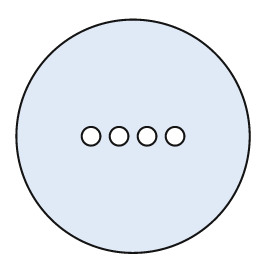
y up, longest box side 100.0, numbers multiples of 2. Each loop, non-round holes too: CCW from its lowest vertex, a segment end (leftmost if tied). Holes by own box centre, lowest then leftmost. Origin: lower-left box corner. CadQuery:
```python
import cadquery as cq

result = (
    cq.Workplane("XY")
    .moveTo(50.0, 50.0)
    .circle(50.0)
    .moveTo(32.0, 50.0)
    .circle(4.0)
    .moveTo(44.0, 50.0)
    .circle(4.0)
    .moveTo(56.0, 50.0)
    .circle(4.0)
    .moveTo(68.0, 50.0)
    .circle(4.0)
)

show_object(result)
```